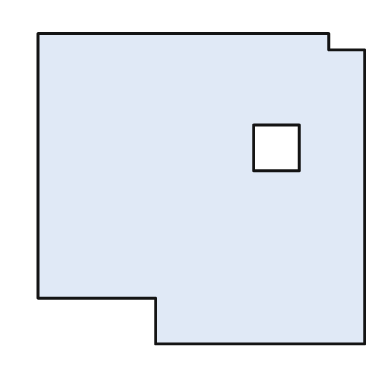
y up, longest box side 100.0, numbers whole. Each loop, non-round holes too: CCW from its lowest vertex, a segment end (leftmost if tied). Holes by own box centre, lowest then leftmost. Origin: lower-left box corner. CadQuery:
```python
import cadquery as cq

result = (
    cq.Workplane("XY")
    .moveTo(36.0, 0.0)
    .lineTo(100.0, 0.0)
    .lineTo(100.0, 90.0)
    .lineTo(89.0, 90.0)
    .lineTo(89.0, 95.0)
    .lineTo(0.0, 95.0)
    .lineTo(0.0, 14.0)
    .lineTo(36.0, 14.0)
    .close()
    .moveTo(66.0, 53.0)
    .lineTo(80.0, 53.0)
    .lineTo(80.0, 67.0)
    .lineTo(66.0, 67.0)
    .close()
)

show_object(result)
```